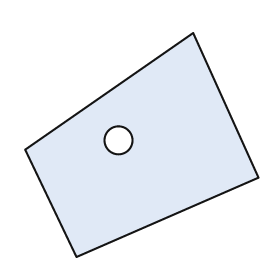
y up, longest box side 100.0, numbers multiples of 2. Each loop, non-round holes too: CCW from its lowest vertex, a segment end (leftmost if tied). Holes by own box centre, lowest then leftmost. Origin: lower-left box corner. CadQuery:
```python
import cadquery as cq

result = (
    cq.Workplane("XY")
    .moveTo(22.0, 0.0)
    .lineTo(100.0, 34.0)
    .lineTo(72.0, 96.0)
    .lineTo(0.0, 46.0)
    .close()
    .moveTo(40.0, 50.0)
    .circle(6.0)
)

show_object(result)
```